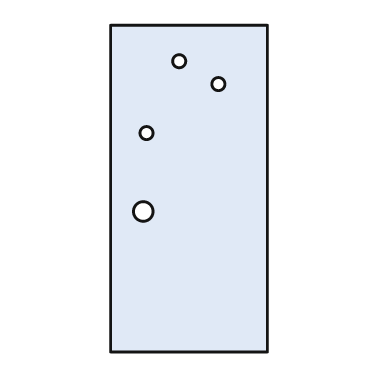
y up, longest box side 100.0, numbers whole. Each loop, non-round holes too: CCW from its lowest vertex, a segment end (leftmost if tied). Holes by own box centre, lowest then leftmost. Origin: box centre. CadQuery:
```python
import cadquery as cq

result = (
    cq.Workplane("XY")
    .moveTo(-24.0, -50.0)
    .lineTo(24.0, -50.0)
    .lineTo(24.0, 50.0)
    .lineTo(-24.0, 50.0)
    .close()
    .moveTo(-14.0, -7.0)
    .circle(3.0)
    .moveTo(-13.0, 17.0)
    .circle(2.0)
    .moveTo(9.0, 32.0)
    .circle(2.0)
    .moveTo(-3.0, 39.0)
    .circle(2.0)
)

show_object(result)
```